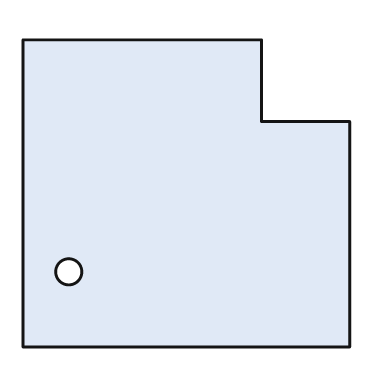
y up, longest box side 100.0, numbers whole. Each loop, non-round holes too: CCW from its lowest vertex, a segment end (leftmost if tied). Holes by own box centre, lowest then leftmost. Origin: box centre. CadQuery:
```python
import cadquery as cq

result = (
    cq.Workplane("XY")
    .moveTo(-50.0, -47.0)
    .lineTo(50.0, -47.0)
    .lineTo(50.0, 22.0)
    .lineTo(23.0, 22.0)
    .lineTo(23.0, 47.0)
    .lineTo(-50.0, 47.0)
    .close()
    .moveTo(-36.0, -24.0)
    .circle(4.0)
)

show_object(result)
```